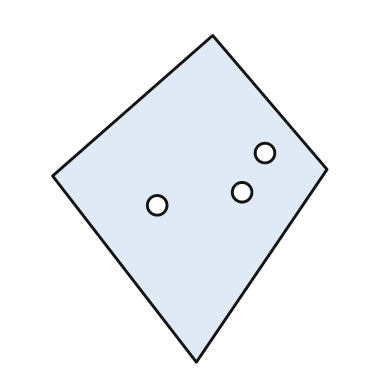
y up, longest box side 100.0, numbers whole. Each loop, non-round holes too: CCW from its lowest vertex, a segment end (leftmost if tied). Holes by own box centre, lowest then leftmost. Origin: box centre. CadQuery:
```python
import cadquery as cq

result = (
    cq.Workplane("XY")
    .moveTo(2.0, -50.0)
    .lineTo(42.0, 9.0)
    .lineTo(7.0, 50.0)
    .lineTo(-42.0, 7.0)
    .close()
    .moveTo(-10.0, -2.0)
    .circle(3.0)
    .moveTo(16.0, 2.0)
    .circle(3.0)
    .moveTo(23.0, 14.0)
    .circle(3.0)
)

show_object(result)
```